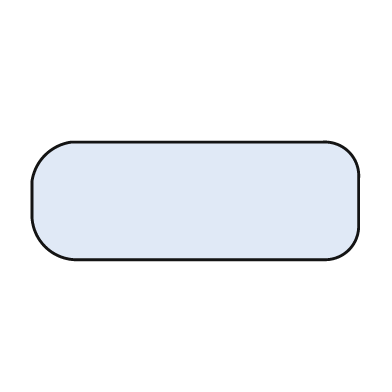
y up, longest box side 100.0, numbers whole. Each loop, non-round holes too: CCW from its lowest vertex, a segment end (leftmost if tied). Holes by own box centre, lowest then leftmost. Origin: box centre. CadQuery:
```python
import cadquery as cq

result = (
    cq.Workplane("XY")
    .moveTo(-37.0, -18.0)
    .lineTo(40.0, -18.0)
    .threePointArc((47.0, -15.0), (50.0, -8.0))
    .lineTo(50.0, 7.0)
    .threePointArc((47.0, 15.0), (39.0, 18.0))
    .lineTo(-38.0, 18.0)
    .threePointArc((-46.0, 14.0), (-50.0, 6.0))
    .lineTo(-50.0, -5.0)
    .threePointArc((-46.0, -14.0), (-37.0, -18.0))
    .close()
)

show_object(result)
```